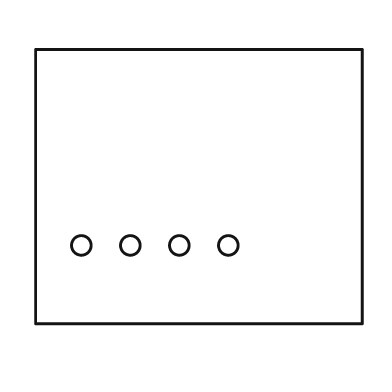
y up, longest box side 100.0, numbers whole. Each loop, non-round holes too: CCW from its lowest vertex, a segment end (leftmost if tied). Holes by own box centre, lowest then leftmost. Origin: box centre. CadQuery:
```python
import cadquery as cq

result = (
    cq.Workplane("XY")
    .moveTo(-50.0, -42.0)
    .lineTo(50.0, -42.0)
    .lineTo(50.0, 42.0)
    .lineTo(-50.0, 42.0)
    .close()
    .moveTo(-36.0, -18.0)
    .circle(3.0)
    .moveTo(-21.0, -18.0)
    .circle(3.0)
    .moveTo(-6.0, -18.0)
    .circle(3.0)
    .moveTo(9.0, -18.0)
    .circle(3.0)
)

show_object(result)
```